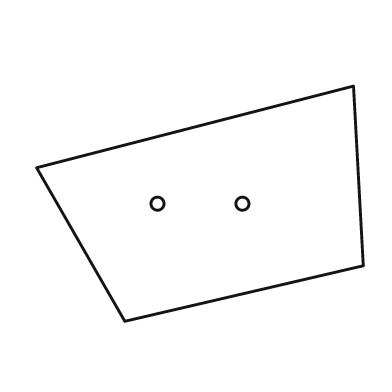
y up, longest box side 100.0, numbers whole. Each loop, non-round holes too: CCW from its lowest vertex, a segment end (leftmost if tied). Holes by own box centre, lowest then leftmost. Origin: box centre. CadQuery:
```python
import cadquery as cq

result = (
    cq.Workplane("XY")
    .moveTo(-23.0, -36.0)
    .lineTo(50.0, -19.0)
    .lineTo(47.0, 36.0)
    .lineTo(-50.0, 11.0)
    .close()
    .moveTo(-13.0, 0.0)
    .circle(2.0)
    .moveTo(13.0, 0.0)
    .circle(2.0)
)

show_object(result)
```